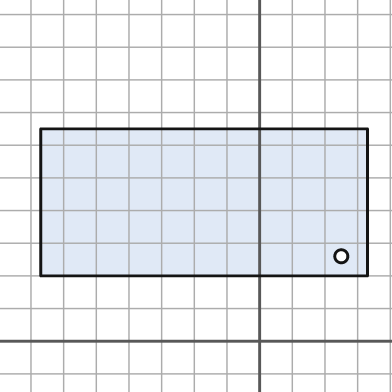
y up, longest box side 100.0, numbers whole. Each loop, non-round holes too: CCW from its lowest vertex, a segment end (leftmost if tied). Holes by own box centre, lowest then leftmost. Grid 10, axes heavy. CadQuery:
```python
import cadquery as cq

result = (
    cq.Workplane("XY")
    .moveTo(-67.0, 20.0)
    .lineTo(33.0, 20.0)
    .lineTo(33.0, 65.0)
    .lineTo(-67.0, 65.0)
    .close()
    .moveTo(25.0, 26.0)
    .circle(2.0)
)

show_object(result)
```